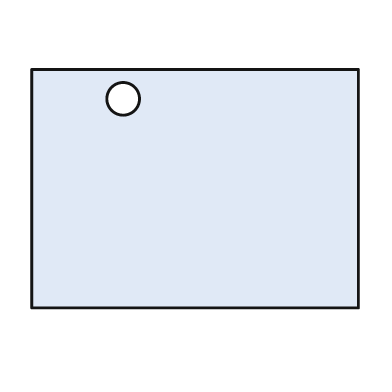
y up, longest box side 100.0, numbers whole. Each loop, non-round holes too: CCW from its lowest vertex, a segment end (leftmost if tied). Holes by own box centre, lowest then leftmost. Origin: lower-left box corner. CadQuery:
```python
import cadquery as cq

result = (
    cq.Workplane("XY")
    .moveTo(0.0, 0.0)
    .lineTo(100.0, 0.0)
    .lineTo(100.0, 73.0)
    .lineTo(0.0, 73.0)
    .close()
    .moveTo(28.0, 64.0)
    .circle(5.0)
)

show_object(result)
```